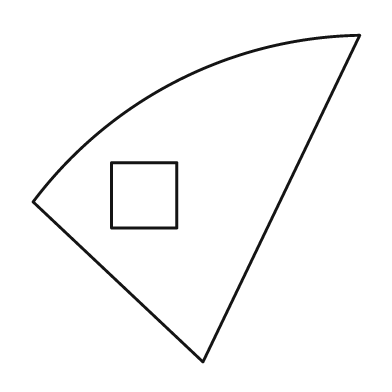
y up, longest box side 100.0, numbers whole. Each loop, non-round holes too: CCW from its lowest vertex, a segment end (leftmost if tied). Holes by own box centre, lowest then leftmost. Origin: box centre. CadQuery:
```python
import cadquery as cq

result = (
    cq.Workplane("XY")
    .moveTo(2.0, -50.0)
    .lineTo(50.0, 50.0)
    .threePointArc((-6.0, 36.0), (-50.0, -1.0))
    .close()
    .moveTo(-26.0, -9.0)
    .lineTo(-6.0, -9.0)
    .lineTo(-6.0, 11.0)
    .lineTo(-26.0, 11.0)
    .close()
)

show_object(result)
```